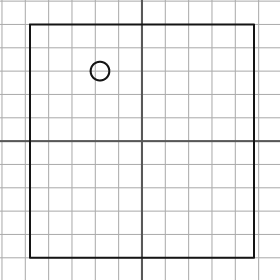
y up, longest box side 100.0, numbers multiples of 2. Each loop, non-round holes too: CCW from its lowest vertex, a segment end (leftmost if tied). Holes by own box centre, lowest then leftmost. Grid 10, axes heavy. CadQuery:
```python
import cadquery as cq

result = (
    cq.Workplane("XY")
    .moveTo(-48.0, -50.0)
    .lineTo(48.0, -50.0)
    .lineTo(48.0, 50.0)
    .lineTo(-48.0, 50.0)
    .close()
    .moveTo(-18.0, 30.0)
    .circle(4.0)
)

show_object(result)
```